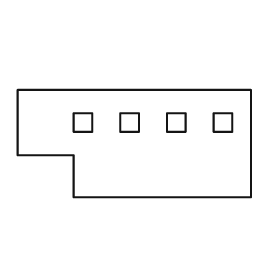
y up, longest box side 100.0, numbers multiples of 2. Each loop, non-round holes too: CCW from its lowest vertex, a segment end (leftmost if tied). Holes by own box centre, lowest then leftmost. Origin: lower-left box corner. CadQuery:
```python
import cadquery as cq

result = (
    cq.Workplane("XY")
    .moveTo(24.0, 0.0)
    .lineTo(100.0, 0.0)
    .lineTo(100.0, 46.0)
    .lineTo(0.0, 46.0)
    .lineTo(0.0, 18.0)
    .lineTo(24.0, 18.0)
    .close()
    .moveTo(24.0, 28.0)
    .lineTo(32.0, 28.0)
    .lineTo(32.0, 36.0)
    .lineTo(24.0, 36.0)
    .close()
    .moveTo(44.0, 28.0)
    .lineTo(52.0, 28.0)
    .lineTo(52.0, 36.0)
    .lineTo(44.0, 36.0)
    .close()
    .moveTo(64.0, 28.0)
    .lineTo(72.0, 28.0)
    .lineTo(72.0, 36.0)
    .lineTo(64.0, 36.0)
    .close()
    .moveTo(84.0, 28.0)
    .lineTo(92.0, 28.0)
    .lineTo(92.0, 36.0)
    .lineTo(84.0, 36.0)
    .close()
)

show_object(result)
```